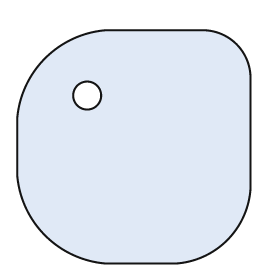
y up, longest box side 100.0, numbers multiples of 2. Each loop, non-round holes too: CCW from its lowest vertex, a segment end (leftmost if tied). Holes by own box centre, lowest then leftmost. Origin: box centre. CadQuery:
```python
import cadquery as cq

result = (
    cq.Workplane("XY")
    .moveTo(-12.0, -50.0)
    .lineTo(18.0, -50.0)
    .threePointArc((40.0, -40.0), (50.0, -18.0))
    .lineTo(50.0, 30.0)
    .threePointArc((44.0, 44.0), (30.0, 50.0))
    .lineTo(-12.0, 50.0)
    .threePointArc((-38.0, 38.0), (-50.0, 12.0))
    .lineTo(-50.0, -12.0)
    .threePointArc((-38.0, -38.0), (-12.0, -50.0))
    .close()
    .moveTo(-20.0, 22.0)
    .circle(6.0)
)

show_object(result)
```